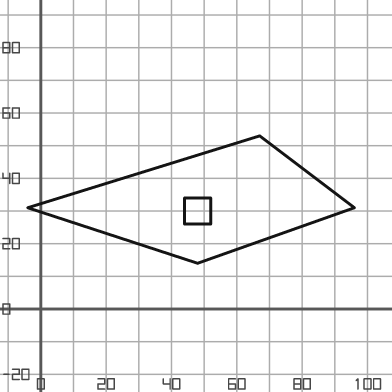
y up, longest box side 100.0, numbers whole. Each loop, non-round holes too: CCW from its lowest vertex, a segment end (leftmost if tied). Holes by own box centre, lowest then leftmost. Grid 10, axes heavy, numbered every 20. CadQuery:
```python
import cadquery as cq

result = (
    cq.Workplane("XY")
    .moveTo(48.0, 14.0)
    .lineTo(96.0, 31.0)
    .lineTo(67.0, 53.0)
    .lineTo(-4.0, 31.0)
    .close()
    .moveTo(44.0, 26.0)
    .lineTo(52.0, 26.0)
    .lineTo(52.0, 34.0)
    .lineTo(44.0, 34.0)
    .close()
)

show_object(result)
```